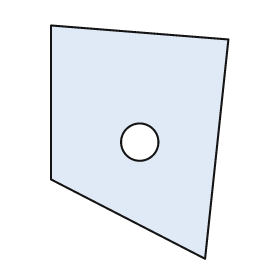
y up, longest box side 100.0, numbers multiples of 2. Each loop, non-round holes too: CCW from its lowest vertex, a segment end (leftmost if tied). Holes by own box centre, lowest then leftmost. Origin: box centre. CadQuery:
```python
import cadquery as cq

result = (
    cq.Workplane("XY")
    .moveTo(28.0, -50.0)
    .lineTo(38.0, 44.0)
    .lineTo(-38.0, 50.0)
    .lineTo(-38.0, -16.0)
    .close()
    .moveTo(0.0, 0.0)
    .circle(8.0)
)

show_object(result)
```